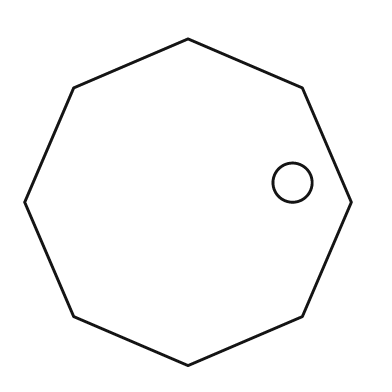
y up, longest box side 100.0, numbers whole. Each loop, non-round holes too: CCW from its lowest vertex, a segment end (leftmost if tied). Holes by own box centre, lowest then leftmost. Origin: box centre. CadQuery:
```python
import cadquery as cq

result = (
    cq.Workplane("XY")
    .moveTo(0.0, -50.0)
    .lineTo(35.0, -35.0)
    .lineTo(50.0, 0.0)
    .lineTo(35.0, 35.0)
    .lineTo(0.0, 50.0)
    .lineTo(-35.0, 35.0)
    .lineTo(-50.0, 0.0)
    .lineTo(-35.0, -35.0)
    .close()
    .moveTo(32.0, 6.0)
    .circle(6.0)
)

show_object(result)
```